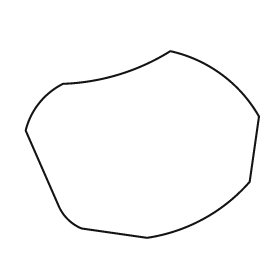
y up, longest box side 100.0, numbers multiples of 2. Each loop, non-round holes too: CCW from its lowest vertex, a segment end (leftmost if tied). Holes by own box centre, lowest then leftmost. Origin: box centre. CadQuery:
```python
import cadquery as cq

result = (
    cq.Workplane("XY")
    .moveTo(2.0, -40.0)
    .threePointArc((26.0, -32.0), (46.0, -16.0))
    .lineTo(50.0, 12.0)
    .threePointArc((34.0, 30.0), (12.0, 40.0))
    .threePointArc((-10.0, 30.0), (-34.0, 26.0))
    .threePointArc((-44.0, 18.0), (-50.0, 6.0))
    .lineTo(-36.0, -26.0)
    .threePointArc((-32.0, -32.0), (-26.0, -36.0))
    .close()
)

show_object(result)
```